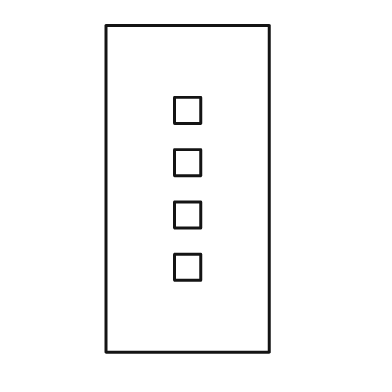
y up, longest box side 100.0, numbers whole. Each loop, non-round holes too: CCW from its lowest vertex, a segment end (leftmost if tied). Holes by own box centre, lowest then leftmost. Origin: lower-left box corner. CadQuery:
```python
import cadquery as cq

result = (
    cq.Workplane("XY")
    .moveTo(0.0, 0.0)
    .lineTo(50.0, 0.0)
    .lineTo(50.0, 100.0)
    .lineTo(0.0, 100.0)
    .close()
    .moveTo(21.0, 22.0)
    .lineTo(29.0, 22.0)
    .lineTo(29.0, 30.0)
    .lineTo(21.0, 30.0)
    .close()
    .moveTo(21.0, 38.0)
    .lineTo(29.0, 38.0)
    .lineTo(29.0, 46.0)
    .lineTo(21.0, 46.0)
    .close()
    .moveTo(21.0, 54.0)
    .lineTo(29.0, 54.0)
    .lineTo(29.0, 62.0)
    .lineTo(21.0, 62.0)
    .close()
    .moveTo(21.0, 70.0)
    .lineTo(29.0, 70.0)
    .lineTo(29.0, 78.0)
    .lineTo(21.0, 78.0)
    .close()
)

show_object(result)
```